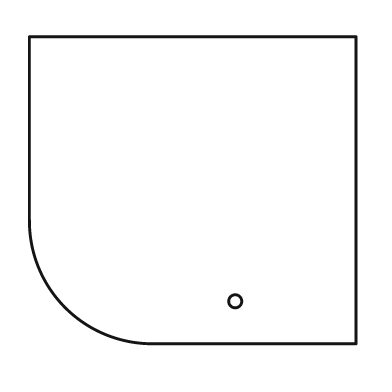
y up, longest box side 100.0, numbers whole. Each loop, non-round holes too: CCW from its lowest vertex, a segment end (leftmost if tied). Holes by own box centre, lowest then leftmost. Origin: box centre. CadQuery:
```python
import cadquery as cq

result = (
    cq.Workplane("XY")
    .moveTo(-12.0, -47.0)
    .lineTo(50.0, -47.0)
    .lineTo(50.0, 47.0)
    .lineTo(-50.0, 47.0)
    .lineTo(-50.0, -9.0)
    .threePointArc((-39.0, -36.0), (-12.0, -47.0))
    .close()
    .moveTo(13.0, -34.0)
    .circle(2.0)
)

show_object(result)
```